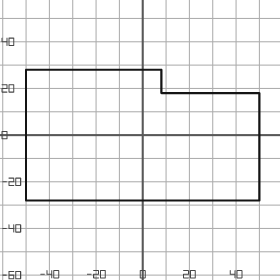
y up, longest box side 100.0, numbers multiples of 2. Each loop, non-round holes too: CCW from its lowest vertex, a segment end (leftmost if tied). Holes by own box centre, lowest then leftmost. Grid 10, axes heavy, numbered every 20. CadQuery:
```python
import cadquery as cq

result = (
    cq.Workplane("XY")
    .moveTo(-50.0, -28.0)
    .lineTo(50.0, -28.0)
    .lineTo(50.0, 18.0)
    .lineTo(8.0, 18.0)
    .lineTo(8.0, 28.0)
    .lineTo(-50.0, 28.0)
    .close()
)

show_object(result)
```